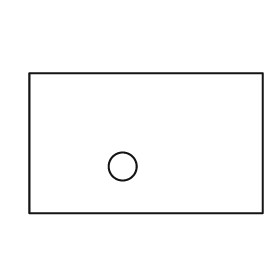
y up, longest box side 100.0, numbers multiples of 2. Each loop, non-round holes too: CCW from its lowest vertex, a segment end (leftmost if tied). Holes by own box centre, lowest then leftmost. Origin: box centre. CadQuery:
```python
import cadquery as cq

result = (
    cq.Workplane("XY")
    .moveTo(-50.0, -30.0)
    .lineTo(50.0, -30.0)
    .lineTo(50.0, 30.0)
    .lineTo(-50.0, 30.0)
    .close()
    .moveTo(-10.0, -10.0)
    .circle(6.0)
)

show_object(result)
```